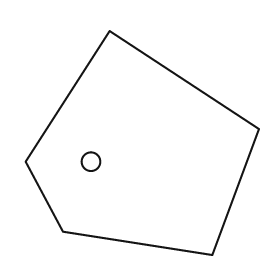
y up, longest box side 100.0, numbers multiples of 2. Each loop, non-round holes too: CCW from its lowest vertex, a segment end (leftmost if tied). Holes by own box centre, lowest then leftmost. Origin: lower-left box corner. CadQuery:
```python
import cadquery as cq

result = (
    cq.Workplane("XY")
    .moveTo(80.0, 0.0)
    .lineTo(100.0, 54.0)
    .lineTo(36.0, 96.0)
    .lineTo(0.0, 40.0)
    .lineTo(16.0, 10.0)
    .close()
    .moveTo(28.0, 40.0)
    .circle(4.0)
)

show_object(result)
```